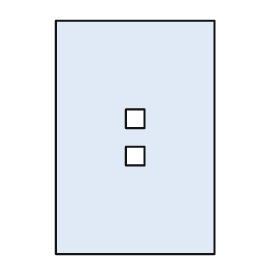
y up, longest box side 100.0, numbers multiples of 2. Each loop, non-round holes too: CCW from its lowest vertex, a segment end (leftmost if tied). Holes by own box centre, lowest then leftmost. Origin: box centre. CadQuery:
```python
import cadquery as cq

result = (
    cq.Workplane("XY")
    .moveTo(-34.0, -50.0)
    .lineTo(34.0, -50.0)
    .lineTo(34.0, 50.0)
    .lineTo(-34.0, 50.0)
    .close()
    .moveTo(-4.0, -12.0)
    .lineTo(4.0, -12.0)
    .lineTo(4.0, -4.0)
    .lineTo(-4.0, -4.0)
    .close()
    .moveTo(-4.0, 4.0)
    .lineTo(4.0, 4.0)
    .lineTo(4.0, 12.0)
    .lineTo(-4.0, 12.0)
    .close()
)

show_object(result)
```